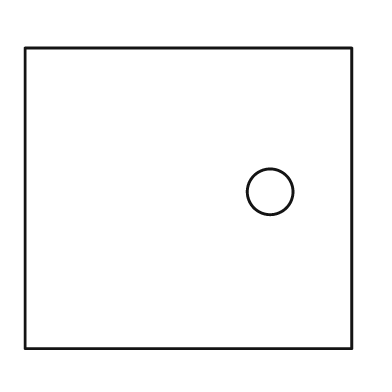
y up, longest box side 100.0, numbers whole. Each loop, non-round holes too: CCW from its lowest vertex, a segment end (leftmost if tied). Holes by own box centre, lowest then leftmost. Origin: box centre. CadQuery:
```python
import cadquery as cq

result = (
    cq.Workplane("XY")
    .moveTo(-50.0, -46.0)
    .lineTo(50.0, -46.0)
    .lineTo(50.0, 46.0)
    .lineTo(-50.0, 46.0)
    .close()
    .moveTo(25.0, 2.0)
    .circle(7.0)
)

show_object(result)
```